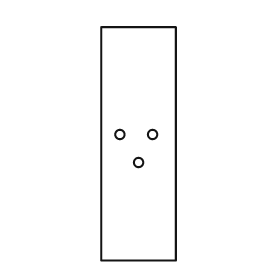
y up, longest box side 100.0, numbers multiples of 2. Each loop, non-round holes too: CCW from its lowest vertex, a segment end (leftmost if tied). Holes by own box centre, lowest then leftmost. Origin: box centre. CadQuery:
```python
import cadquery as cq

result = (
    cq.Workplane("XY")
    .moveTo(-16.0, -50.0)
    .lineTo(16.0, -50.0)
    .lineTo(16.0, 50.0)
    .lineTo(-16.0, 50.0)
    .close()
    .moveTo(0.0, -8.0)
    .circle(2.0)
    .moveTo(-8.0, 4.0)
    .circle(2.0)
    .moveTo(6.0, 4.0)
    .circle(2.0)
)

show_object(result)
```